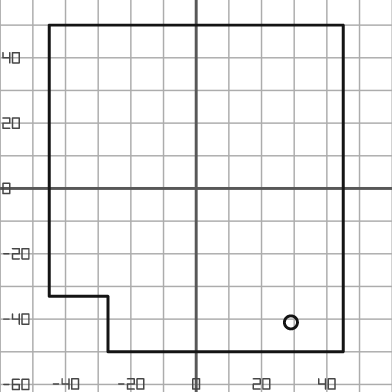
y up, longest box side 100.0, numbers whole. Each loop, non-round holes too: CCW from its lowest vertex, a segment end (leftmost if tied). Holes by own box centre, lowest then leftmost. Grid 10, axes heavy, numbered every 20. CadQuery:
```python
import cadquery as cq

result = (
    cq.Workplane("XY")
    .moveTo(-27.0, -50.0)
    .lineTo(45.0, -50.0)
    .lineTo(45.0, 50.0)
    .lineTo(-45.0, 50.0)
    .lineTo(-45.0, -33.0)
    .lineTo(-27.0, -33.0)
    .close()
    .moveTo(29.0, -41.0)
    .circle(2.0)
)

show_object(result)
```